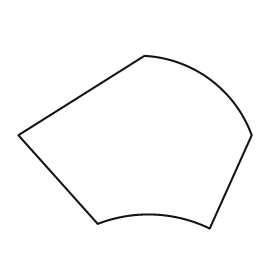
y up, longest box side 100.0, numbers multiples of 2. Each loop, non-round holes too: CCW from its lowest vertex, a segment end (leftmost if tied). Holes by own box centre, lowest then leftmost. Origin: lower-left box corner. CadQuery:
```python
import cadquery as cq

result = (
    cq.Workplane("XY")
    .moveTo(82.0, 0.0)
    .lineTo(100.0, 40.0)
    .threePointArc((82.0, 64.0), (54.0, 74.0))
    .lineTo(0.0, 40.0)
    .lineTo(34.0, 2.0)
    .threePointArc((58.0, 6.0), (82.0, 0.0))
    .close()
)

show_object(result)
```